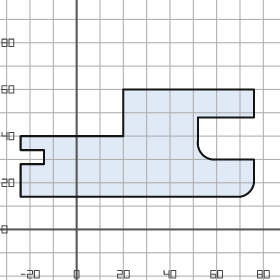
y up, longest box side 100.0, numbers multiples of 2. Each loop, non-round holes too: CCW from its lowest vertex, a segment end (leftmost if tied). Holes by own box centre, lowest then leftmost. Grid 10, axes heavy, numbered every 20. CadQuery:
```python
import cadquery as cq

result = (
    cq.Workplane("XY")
    .moveTo(-24.0, 14.0)
    .lineTo(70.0, 14.0)
    .threePointArc((74.0, 16.0), (76.0, 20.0))
    .lineTo(76.0, 30.0)
    .lineTo(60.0, 30.0)
    .threePointArc((54.0, 32.0), (52.0, 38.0))
    .lineTo(52.0, 48.0)
    .lineTo(76.0, 48.0)
    .lineTo(76.0, 60.0)
    .lineTo(20.0, 60.0)
    .lineTo(20.0, 40.0)
    .lineTo(-24.0, 40.0)
    .lineTo(-24.0, 34.0)
    .lineTo(-14.0, 34.0)
    .lineTo(-14.0, 28.0)
    .lineTo(-24.0, 28.0)
    .close()
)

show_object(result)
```